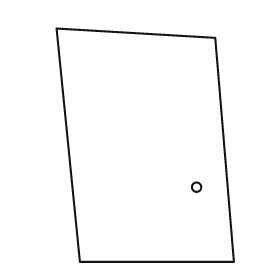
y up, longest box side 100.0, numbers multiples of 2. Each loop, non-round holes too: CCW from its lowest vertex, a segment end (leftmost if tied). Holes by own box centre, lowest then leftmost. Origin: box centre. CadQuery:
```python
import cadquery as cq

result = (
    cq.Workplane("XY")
    .moveTo(-28.0, -50.0)
    .lineTo(38.0, -50.0)
    .lineTo(30.0, 46.0)
    .lineTo(-38.0, 50.0)
    .close()
    .moveTo(22.0, -18.0)
    .circle(2.0)
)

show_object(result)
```